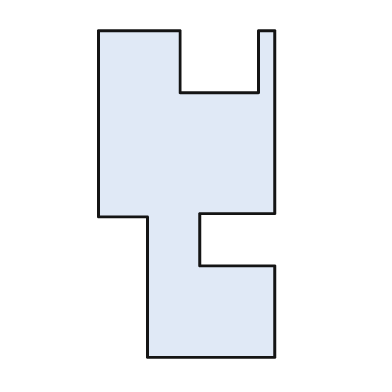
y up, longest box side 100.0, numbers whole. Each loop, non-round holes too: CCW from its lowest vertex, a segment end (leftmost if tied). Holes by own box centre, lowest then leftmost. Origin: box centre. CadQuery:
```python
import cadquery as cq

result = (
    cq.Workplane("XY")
    .moveTo(-12.0, -50.0)
    .lineTo(27.0, -50.0)
    .lineTo(27.0, -22.0)
    .lineTo(4.0, -22.0)
    .lineTo(4.0, -6.0)
    .lineTo(27.0, -6.0)
    .lineTo(27.0, 50.0)
    .lineTo(22.0, 50.0)
    .lineTo(22.0, 31.0)
    .lineTo(-2.0, 31.0)
    .lineTo(-2.0, 50.0)
    .lineTo(-27.0, 50.0)
    .lineTo(-27.0, -7.0)
    .lineTo(-12.0, -7.0)
    .close()
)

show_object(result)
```